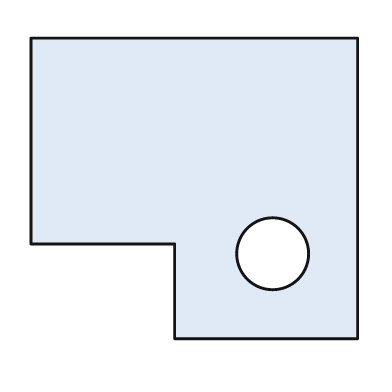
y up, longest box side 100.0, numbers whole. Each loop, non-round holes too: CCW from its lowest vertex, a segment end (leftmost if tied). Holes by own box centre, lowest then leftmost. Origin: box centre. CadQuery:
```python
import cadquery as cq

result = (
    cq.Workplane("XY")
    .moveTo(-6.0, -46.0)
    .lineTo(50.0, -46.0)
    .lineTo(50.0, 46.0)
    .lineTo(-50.0, 46.0)
    .lineTo(-50.0, -17.0)
    .lineTo(-6.0, -17.0)
    .close()
    .moveTo(24.0, -20.0)
    .circle(11.0)
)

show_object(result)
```